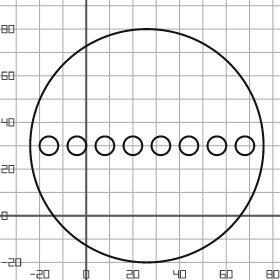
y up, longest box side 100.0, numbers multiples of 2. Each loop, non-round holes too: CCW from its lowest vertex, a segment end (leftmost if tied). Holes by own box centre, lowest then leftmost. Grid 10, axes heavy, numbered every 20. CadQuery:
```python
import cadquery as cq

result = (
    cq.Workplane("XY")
    .moveTo(26.0, 30.0)
    .circle(50.0)
    .moveTo(-16.0, 30.0)
    .circle(4.0)
    .moveTo(-4.0, 30.0)
    .circle(4.0)
    .moveTo(8.0, 30.0)
    .circle(4.0)
    .moveTo(20.0, 30.0)
    .circle(4.0)
    .moveTo(32.0, 30.0)
    .circle(4.0)
    .moveTo(44.0, 30.0)
    .circle(4.0)
    .moveTo(56.0, 30.0)
    .circle(4.0)
    .moveTo(68.0, 30.0)
    .circle(4.0)
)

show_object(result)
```